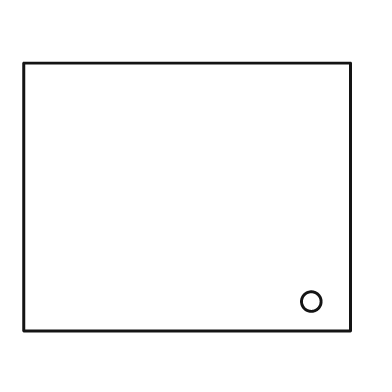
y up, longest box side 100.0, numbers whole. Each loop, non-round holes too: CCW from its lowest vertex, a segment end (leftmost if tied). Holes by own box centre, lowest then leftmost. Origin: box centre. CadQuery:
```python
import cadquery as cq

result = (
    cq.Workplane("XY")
    .moveTo(-50.0, -41.0)
    .lineTo(50.0, -41.0)
    .lineTo(50.0, 41.0)
    .lineTo(-50.0, 41.0)
    .close()
    .moveTo(38.0, -32.0)
    .circle(3.0)
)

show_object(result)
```